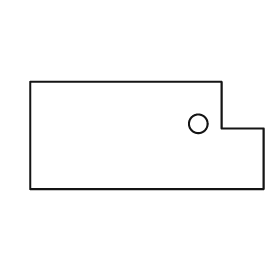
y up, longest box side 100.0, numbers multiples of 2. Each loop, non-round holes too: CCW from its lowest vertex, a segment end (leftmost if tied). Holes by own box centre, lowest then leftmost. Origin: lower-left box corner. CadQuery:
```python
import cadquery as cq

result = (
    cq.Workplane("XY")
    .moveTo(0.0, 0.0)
    .lineTo(100.0, 0.0)
    .lineTo(100.0, 26.0)
    .lineTo(82.0, 26.0)
    .lineTo(82.0, 46.0)
    .lineTo(0.0, 46.0)
    .close()
    .moveTo(72.0, 28.0)
    .circle(4.0)
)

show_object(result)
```